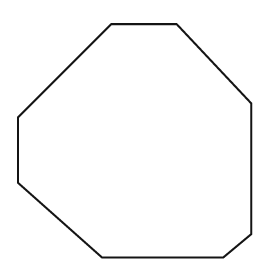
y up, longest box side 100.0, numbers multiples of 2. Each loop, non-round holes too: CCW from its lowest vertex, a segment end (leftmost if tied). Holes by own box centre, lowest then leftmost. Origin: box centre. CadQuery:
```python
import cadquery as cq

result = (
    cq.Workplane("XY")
    .moveTo(-14.0, -50.0)
    .lineTo(38.0, -50.0)
    .lineTo(50.0, -40.0)
    .lineTo(50.0, 16.0)
    .lineTo(18.0, 50.0)
    .lineTo(-10.0, 50.0)
    .lineTo(-50.0, 10.0)
    .lineTo(-50.0, -18.0)
    .close()
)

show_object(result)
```